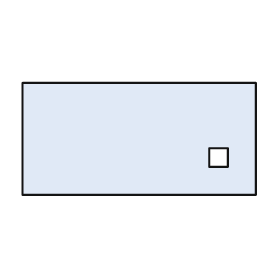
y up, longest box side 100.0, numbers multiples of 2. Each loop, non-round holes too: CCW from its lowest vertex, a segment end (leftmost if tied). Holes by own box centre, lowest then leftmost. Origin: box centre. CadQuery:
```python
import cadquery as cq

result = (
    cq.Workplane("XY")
    .moveTo(-50.0, -24.0)
    .lineTo(50.0, -24.0)
    .lineTo(50.0, 24.0)
    .lineTo(-50.0, 24.0)
    .close()
    .moveTo(30.0, -12.0)
    .lineTo(38.0, -12.0)
    .lineTo(38.0, -4.0)
    .lineTo(30.0, -4.0)
    .close()
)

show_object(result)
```